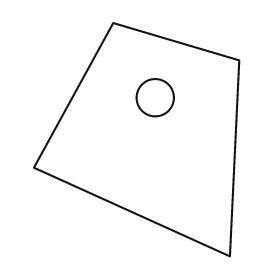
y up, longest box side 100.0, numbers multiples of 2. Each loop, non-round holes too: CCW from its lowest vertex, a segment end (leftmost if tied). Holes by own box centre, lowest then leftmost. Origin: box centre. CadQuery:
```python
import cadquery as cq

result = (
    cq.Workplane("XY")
    .moveTo(40.0, -50.0)
    .lineTo(44.0, 34.0)
    .lineTo(-10.0, 50.0)
    .lineTo(-44.0, -12.0)
    .close()
    .moveTo(8.0, 18.0)
    .circle(8.0)
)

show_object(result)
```